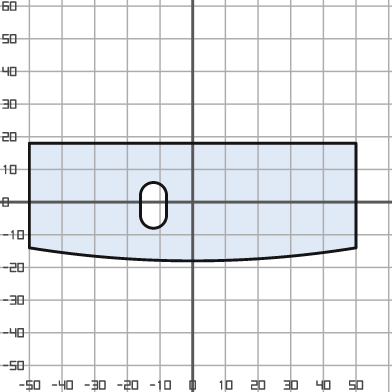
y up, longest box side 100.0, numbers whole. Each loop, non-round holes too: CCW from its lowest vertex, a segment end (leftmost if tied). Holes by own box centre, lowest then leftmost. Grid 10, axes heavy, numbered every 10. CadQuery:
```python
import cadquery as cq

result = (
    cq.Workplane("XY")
    .moveTo(-50.0, -14.0)
    .threePointArc((0.0, -18.0), (50.0, -14.0))
    .lineTo(50.0, 18.0)
    .lineTo(-50.0, 18.0)
    .close()
    .moveTo(-16.0, -4.0)
    .threePointArc((-12.0, -8.0), (-8.0, -4.0))
    .lineTo(-8.0, 2.0)
    .threePointArc((-12.0, 6.0), (-16.0, 2.0))
    .close()
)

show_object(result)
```